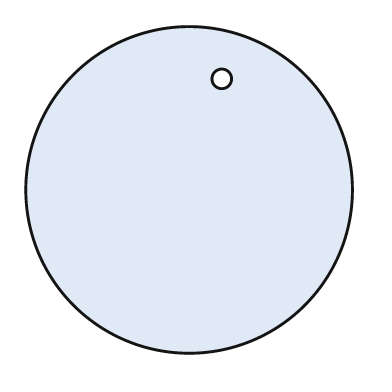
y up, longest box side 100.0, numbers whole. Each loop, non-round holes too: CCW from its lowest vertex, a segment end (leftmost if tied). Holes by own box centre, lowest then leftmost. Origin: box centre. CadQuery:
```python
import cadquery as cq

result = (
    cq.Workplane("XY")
    .moveTo(0.0, 0.0)
    .circle(50.0)
    .moveTo(10.0, 34.0)
    .circle(3.0)
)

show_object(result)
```